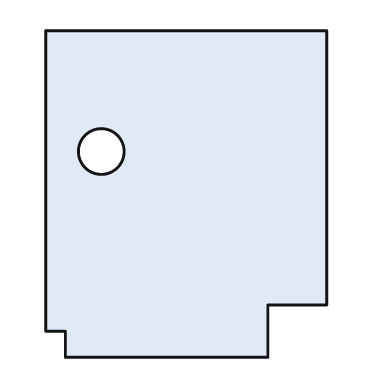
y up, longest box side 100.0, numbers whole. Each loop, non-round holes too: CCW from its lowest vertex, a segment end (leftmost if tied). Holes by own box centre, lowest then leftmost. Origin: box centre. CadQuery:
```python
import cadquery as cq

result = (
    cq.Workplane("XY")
    .moveTo(-37.0, -50.0)
    .lineTo(25.0, -50.0)
    .lineTo(25.0, -34.0)
    .lineTo(43.0, -34.0)
    .lineTo(43.0, 50.0)
    .lineTo(-43.0, 50.0)
    .lineTo(-43.0, -42.0)
    .lineTo(-37.0, -42.0)
    .close()
    .moveTo(-26.0, 13.0)
    .circle(7.0)
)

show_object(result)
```